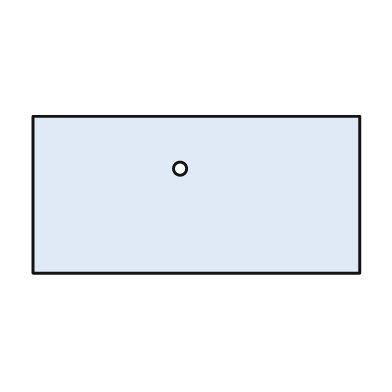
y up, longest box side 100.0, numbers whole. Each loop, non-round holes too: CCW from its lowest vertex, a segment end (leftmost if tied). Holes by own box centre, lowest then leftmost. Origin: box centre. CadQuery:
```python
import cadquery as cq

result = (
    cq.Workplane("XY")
    .moveTo(-50.0, -24.0)
    .lineTo(50.0, -24.0)
    .lineTo(50.0, 24.0)
    .lineTo(-50.0, 24.0)
    .close()
    .moveTo(-5.0, 8.0)
    .circle(2.0)
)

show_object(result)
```